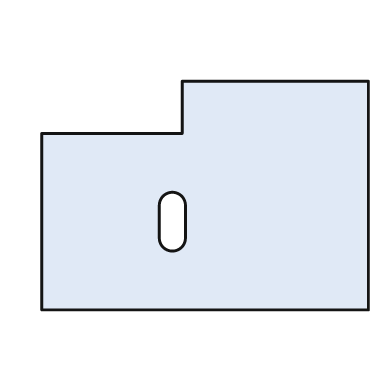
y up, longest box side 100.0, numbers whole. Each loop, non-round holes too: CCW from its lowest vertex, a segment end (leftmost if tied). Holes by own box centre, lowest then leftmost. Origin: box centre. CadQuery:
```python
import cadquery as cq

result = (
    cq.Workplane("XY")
    .moveTo(-50.0, -35.0)
    .lineTo(50.0, -35.0)
    .lineTo(50.0, 35.0)
    .lineTo(-7.0, 35.0)
    .lineTo(-7.0, 19.0)
    .lineTo(-50.0, 19.0)
    .close()
    .moveTo(-14.0, -13.0)
    .threePointArc((-10.0, -17.0), (-6.0, -13.0))
    .lineTo(-6.0, -3.0)
    .threePointArc((-10.0, 1.0), (-14.0, -3.0))
    .close()
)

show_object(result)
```